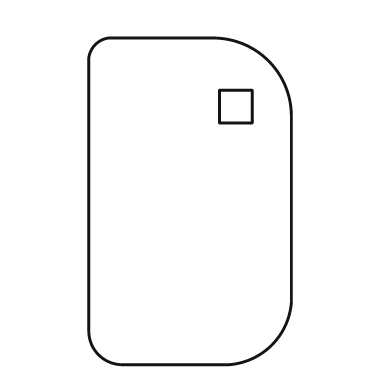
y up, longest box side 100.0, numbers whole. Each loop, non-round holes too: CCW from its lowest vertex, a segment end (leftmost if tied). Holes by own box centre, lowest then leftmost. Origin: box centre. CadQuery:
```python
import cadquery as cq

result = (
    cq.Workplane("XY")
    .moveTo(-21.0, -50.0)
    .lineTo(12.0, -50.0)
    .threePointArc((25.0, -44.0), (31.0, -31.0))
    .lineTo(31.0, 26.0)
    .threePointArc((24.0, 43.0), (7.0, 50.0))
    .lineTo(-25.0, 50.0)
    .threePointArc((-29.0, 48.0), (-31.0, 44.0))
    .lineTo(-31.0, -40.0)
    .threePointArc((-28.0, -47.0), (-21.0, -50.0))
    .close()
    .moveTo(9.0, 24.0)
    .lineTo(19.0, 24.0)
    .lineTo(19.0, 34.0)
    .lineTo(9.0, 34.0)
    .close()
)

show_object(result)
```